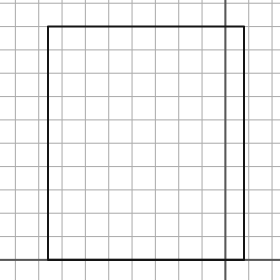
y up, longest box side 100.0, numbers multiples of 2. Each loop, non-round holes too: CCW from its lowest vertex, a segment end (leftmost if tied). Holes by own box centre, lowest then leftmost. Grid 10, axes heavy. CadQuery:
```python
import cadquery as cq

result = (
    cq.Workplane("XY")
    .moveTo(-76.0, 0.0)
    .lineTo(8.0, 0.0)
    .lineTo(8.0, 100.0)
    .lineTo(-76.0, 100.0)
    .close()
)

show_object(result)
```